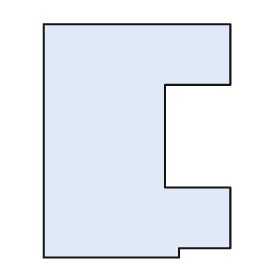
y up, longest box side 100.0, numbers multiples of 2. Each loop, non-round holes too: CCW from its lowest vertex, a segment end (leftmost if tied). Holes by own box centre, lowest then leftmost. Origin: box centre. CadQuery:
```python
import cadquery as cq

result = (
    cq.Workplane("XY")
    .moveTo(-40.0, -50.0)
    .lineTo(18.0, -50.0)
    .lineTo(18.0, -46.0)
    .lineTo(40.0, -46.0)
    .lineTo(40.0, -20.0)
    .lineTo(12.0, -20.0)
    .lineTo(12.0, 24.0)
    .lineTo(40.0, 24.0)
    .lineTo(40.0, 50.0)
    .lineTo(-40.0, 50.0)
    .close()
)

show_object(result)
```